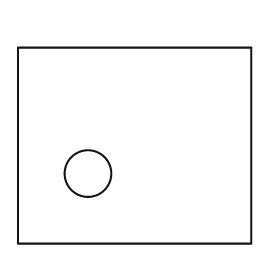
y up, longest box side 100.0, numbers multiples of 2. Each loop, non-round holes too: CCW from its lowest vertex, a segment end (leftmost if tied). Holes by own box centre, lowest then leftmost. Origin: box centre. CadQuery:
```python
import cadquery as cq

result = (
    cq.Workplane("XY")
    .moveTo(-50.0, -42.0)
    .lineTo(50.0, -42.0)
    .lineTo(50.0, 42.0)
    .lineTo(-50.0, 42.0)
    .close()
    .moveTo(-20.0, -12.0)
    .circle(10.0)
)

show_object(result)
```